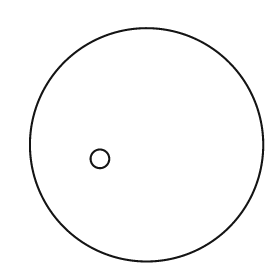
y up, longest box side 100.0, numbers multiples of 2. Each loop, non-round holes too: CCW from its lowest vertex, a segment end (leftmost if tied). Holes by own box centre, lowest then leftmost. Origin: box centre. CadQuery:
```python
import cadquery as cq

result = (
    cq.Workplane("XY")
    .moveTo(0.0, 0.0)
    .circle(50.0)
    .moveTo(-20.0, -6.0)
    .circle(4.0)
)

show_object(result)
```